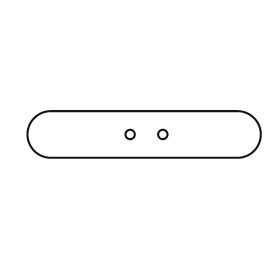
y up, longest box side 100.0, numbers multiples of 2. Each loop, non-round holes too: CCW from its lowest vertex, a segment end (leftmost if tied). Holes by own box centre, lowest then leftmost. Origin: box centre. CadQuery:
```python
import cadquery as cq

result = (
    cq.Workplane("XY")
    .moveTo(-40.0, -10.0)
    .lineTo(40.0, -10.0)
    .threePointArc((50.0, 0.0), (40.0, 10.0))
    .lineTo(-40.0, 10.0)
    .threePointArc((-50.0, 0.0), (-40.0, -10.0))
    .close()
    .moveTo(-6.0, 0.0)
    .circle(2.0)
    .moveTo(8.0, 0.0)
    .circle(2.0)
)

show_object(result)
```